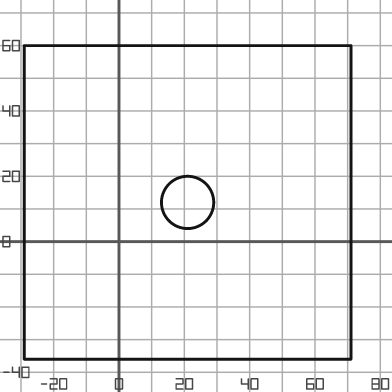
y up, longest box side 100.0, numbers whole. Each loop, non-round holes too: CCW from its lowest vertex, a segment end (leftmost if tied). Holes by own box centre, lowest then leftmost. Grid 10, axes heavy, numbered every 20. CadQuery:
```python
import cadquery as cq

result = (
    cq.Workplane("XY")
    .moveTo(-29.0, -36.0)
    .lineTo(71.0, -36.0)
    .lineTo(71.0, 60.0)
    .lineTo(-29.0, 60.0)
    .close()
    .moveTo(21.0, 12.0)
    .circle(8.0)
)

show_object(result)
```